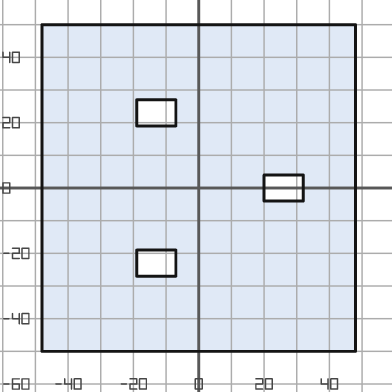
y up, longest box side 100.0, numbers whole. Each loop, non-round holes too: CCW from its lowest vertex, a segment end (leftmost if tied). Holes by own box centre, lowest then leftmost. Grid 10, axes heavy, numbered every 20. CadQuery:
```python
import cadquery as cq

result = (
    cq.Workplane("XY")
    .moveTo(-48.0, -50.0)
    .lineTo(48.0, -50.0)
    .lineTo(48.0, 50.0)
    .lineTo(-48.0, 50.0)
    .close()
    .moveTo(-19.0, -27.0)
    .lineTo(-7.0, -27.0)
    .lineTo(-7.0, -19.0)
    .lineTo(-19.0, -19.0)
    .close()
    .moveTo(20.0, -4.0)
    .lineTo(32.0, -4.0)
    .lineTo(32.0, 4.0)
    .lineTo(20.0, 4.0)
    .close()
    .moveTo(-19.0, 19.0)
    .lineTo(-7.0, 19.0)
    .lineTo(-7.0, 27.0)
    .lineTo(-19.0, 27.0)
    .close()
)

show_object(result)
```